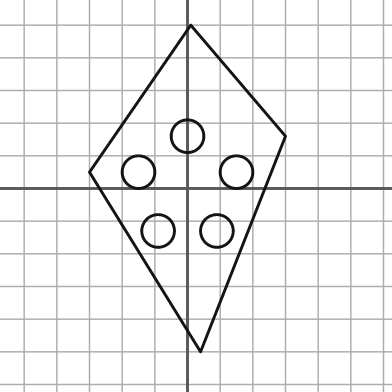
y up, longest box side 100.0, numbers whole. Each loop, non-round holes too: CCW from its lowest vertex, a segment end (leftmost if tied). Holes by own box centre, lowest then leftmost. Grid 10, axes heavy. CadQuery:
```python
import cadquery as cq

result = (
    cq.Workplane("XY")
    .moveTo(4.0, -50.0)
    .lineTo(30.0, 16.0)
    .lineTo(1.0, 50.0)
    .lineTo(-30.0, 5.0)
    .close()
    .moveTo(-9.0, -13.0)
    .circle(5.0)
    .moveTo(9.0, -13.0)
    .circle(5.0)
    .moveTo(-15.0, 5.0)
    .circle(5.0)
    .moveTo(15.0, 5.0)
    .circle(5.0)
    .moveTo(0.0, 16.0)
    .circle(5.0)
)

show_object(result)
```